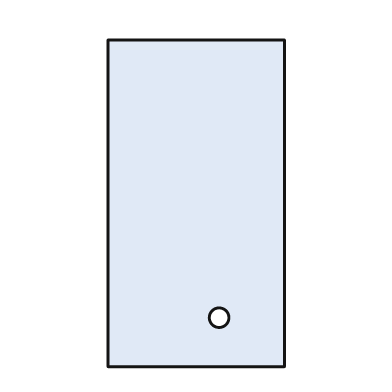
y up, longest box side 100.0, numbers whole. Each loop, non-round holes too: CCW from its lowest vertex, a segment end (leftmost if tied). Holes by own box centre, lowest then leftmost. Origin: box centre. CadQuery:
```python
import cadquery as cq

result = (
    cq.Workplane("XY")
    .moveTo(-27.0, -50.0)
    .lineTo(27.0, -50.0)
    .lineTo(27.0, 50.0)
    .lineTo(-27.0, 50.0)
    .close()
    .moveTo(7.0, -35.0)
    .circle(3.0)
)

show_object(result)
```